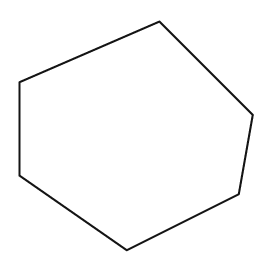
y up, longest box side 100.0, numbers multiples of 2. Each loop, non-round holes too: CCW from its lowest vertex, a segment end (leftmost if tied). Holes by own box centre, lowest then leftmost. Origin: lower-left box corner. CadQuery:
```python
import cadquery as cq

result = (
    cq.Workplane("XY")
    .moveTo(46.0, 0.0)
    .lineTo(94.0, 24.0)
    .lineTo(100.0, 58.0)
    .lineTo(60.0, 98.0)
    .lineTo(0.0, 72.0)
    .lineTo(0.0, 32.0)
    .close()
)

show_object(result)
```